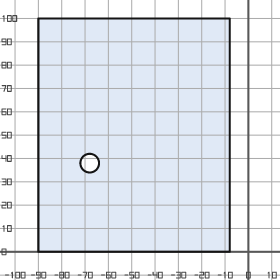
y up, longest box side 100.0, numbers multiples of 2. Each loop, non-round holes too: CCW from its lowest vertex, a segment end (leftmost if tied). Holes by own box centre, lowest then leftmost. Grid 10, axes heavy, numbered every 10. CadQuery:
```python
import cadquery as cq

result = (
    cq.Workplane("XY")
    .moveTo(-90.0, 0.0)
    .lineTo(-8.0, 0.0)
    .lineTo(-8.0, 100.0)
    .lineTo(-90.0, 100.0)
    .close()
    .moveTo(-68.0, 38.0)
    .circle(4.0)
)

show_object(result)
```